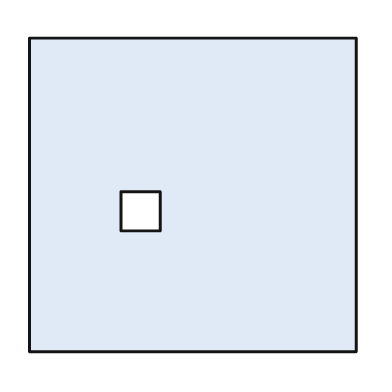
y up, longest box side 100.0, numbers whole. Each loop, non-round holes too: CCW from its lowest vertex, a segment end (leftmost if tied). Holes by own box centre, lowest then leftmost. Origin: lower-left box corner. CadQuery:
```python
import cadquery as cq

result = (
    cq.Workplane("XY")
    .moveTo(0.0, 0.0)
    .lineTo(100.0, 0.0)
    .lineTo(100.0, 96.0)
    .lineTo(0.0, 96.0)
    .close()
    .moveTo(28.0, 37.0)
    .lineTo(40.0, 37.0)
    .lineTo(40.0, 49.0)
    .lineTo(28.0, 49.0)
    .close()
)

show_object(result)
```